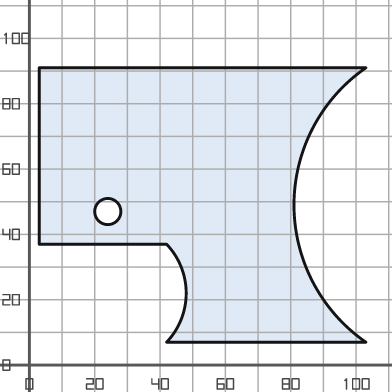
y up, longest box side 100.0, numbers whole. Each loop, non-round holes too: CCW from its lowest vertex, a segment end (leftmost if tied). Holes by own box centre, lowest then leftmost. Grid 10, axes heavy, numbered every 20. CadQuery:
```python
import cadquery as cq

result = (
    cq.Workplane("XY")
    .moveTo(42.0, 7.0)
    .lineTo(103.0, 7.0)
    .threePointArc((81.0, 49.0), (103.0, 91.0))
    .lineTo(3.0, 91.0)
    .lineTo(3.0, 37.0)
    .lineTo(42.0, 37.0)
    .threePointArc((48.0, 22.0), (42.0, 7.0))
    .close()
    .moveTo(24.0, 47.0)
    .circle(4.0)
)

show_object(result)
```